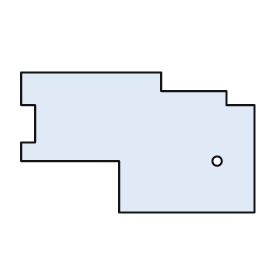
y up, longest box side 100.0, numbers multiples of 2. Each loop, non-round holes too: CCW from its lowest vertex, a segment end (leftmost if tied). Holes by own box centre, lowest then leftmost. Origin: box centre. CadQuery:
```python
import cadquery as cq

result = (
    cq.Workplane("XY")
    .moveTo(-8.0, -30.0)
    .lineTo(50.0, -30.0)
    .lineTo(50.0, 16.0)
    .lineTo(38.0, 16.0)
    .lineTo(38.0, 22.0)
    .lineTo(10.0, 22.0)
    .lineTo(10.0, 30.0)
    .lineTo(-50.0, 30.0)
    .lineTo(-50.0, 16.0)
    .lineTo(-44.0, 16.0)
    .lineTo(-44.0, 0.0)
    .lineTo(-50.0, 0.0)
    .lineTo(-50.0, -8.0)
    .lineTo(-8.0, -8.0)
    .close()
    .moveTo(34.0, -8.0)
    .circle(2.0)
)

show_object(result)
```